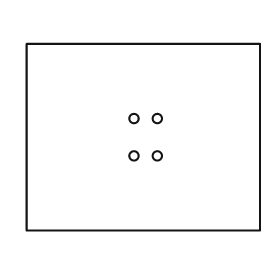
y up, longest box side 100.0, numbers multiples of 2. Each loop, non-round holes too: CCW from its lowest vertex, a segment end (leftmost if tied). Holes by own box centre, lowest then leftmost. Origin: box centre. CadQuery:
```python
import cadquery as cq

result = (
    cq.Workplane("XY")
    .moveTo(-50.0, -40.0)
    .lineTo(50.0, -40.0)
    .lineTo(50.0, 40.0)
    .lineTo(-50.0, 40.0)
    .close()
    .moveTo(-4.0, -8.0)
    .circle(2.0)
    .moveTo(6.0, -8.0)
    .circle(2.0)
    .moveTo(-4.0, 8.0)
    .circle(2.0)
    .moveTo(6.0, 8.0)
    .circle(2.0)
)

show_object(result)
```